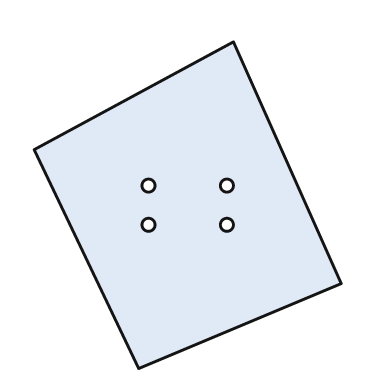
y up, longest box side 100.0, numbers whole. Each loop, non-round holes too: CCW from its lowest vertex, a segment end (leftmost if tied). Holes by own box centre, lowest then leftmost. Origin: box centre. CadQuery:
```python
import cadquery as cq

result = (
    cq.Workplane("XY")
    .moveTo(-15.0, -50.0)
    .lineTo(47.0, -24.0)
    .lineTo(14.0, 50.0)
    .lineTo(-47.0, 17.0)
    .close()
    .moveTo(-12.0, -6.0)
    .circle(2.0)
    .moveTo(12.0, -6.0)
    .circle(2.0)
    .moveTo(-12.0, 6.0)
    .circle(2.0)
    .moveTo(12.0, 6.0)
    .circle(2.0)
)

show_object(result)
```